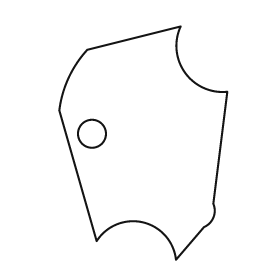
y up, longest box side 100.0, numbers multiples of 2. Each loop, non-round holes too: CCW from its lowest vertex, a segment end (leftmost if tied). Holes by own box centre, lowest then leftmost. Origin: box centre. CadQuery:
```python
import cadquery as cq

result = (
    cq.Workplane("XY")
    .moveTo(14.0, -50.0)
    .lineTo(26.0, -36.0)
    .threePointArc((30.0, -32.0), (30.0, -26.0))
    .lineTo(36.0, 22.0)
    .threePointArc((18.0, 30.0), (16.0, 50.0))
    .lineTo(-24.0, 40.0)
    .threePointArc((-32.0, 28.0), (-36.0, 14.0))
    .lineTo(-20.0, -42.0)
    .threePointArc((0.0, -34.0), (14.0, -50.0))
    .close()
    .moveTo(-22.0, 4.0)
    .circle(6.0)
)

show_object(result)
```